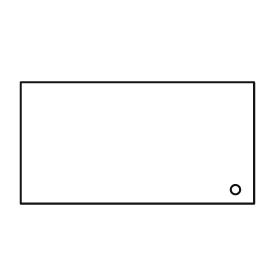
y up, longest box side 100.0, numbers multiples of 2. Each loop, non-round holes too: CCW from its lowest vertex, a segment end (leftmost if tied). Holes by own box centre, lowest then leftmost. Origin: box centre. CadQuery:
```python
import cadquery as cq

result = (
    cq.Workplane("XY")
    .moveTo(-50.0, -26.0)
    .lineTo(50.0, -26.0)
    .lineTo(50.0, 26.0)
    .lineTo(-50.0, 26.0)
    .close()
    .moveTo(42.0, -20.0)
    .circle(2.0)
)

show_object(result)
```